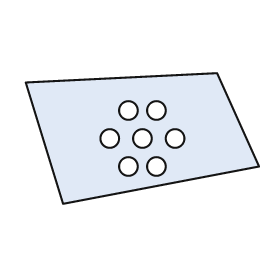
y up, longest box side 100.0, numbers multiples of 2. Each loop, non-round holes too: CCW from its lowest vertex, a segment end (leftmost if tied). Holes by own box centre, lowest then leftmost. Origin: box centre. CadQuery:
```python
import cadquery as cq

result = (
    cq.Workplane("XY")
    .moveTo(-34.0, -28.0)
    .lineTo(50.0, -12.0)
    .lineTo(32.0, 28.0)
    .lineTo(-50.0, 24.0)
    .close()
    .moveTo(-6.0, -12.0)
    .circle(4.0)
    .moveTo(6.0, -12.0)
    .circle(4.0)
    .moveTo(-14.0, 0.0)
    .circle(4.0)
    .moveTo(0.0, 0.0)
    .circle(4.0)
    .moveTo(14.0, 0.0)
    .circle(4.0)
    .moveTo(-6.0, 12.0)
    .circle(4.0)
    .moveTo(6.0, 12.0)
    .circle(4.0)
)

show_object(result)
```